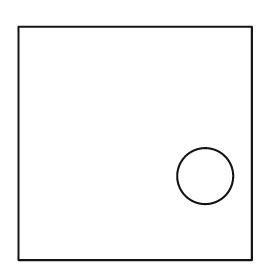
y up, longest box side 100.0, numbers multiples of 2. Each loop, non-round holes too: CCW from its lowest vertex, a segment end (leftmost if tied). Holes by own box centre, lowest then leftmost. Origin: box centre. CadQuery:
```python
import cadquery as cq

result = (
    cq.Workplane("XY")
    .moveTo(-50.0, -50.0)
    .lineTo(50.0, -50.0)
    .lineTo(50.0, 50.0)
    .lineTo(-50.0, 50.0)
    .close()
    .moveTo(30.0, -14.0)
    .circle(12.0)
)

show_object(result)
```